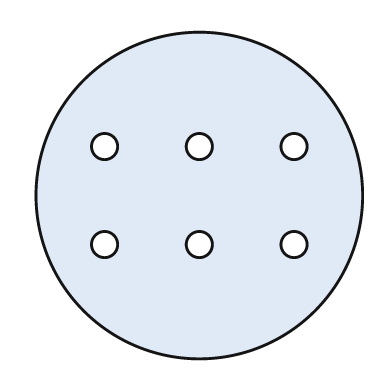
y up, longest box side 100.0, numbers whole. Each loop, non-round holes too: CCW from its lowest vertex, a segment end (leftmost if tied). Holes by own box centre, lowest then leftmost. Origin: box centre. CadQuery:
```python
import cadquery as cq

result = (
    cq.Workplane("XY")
    .moveTo(0.0, 0.0)
    .circle(50.0)
    .moveTo(-29.0, -15.0)
    .circle(4.0)
    .moveTo(0.0, -15.0)
    .circle(4.0)
    .moveTo(29.0, -15.0)
    .circle(4.0)
    .moveTo(-29.0, 15.0)
    .circle(4.0)
    .moveTo(0.0, 15.0)
    .circle(4.0)
    .moveTo(29.0, 15.0)
    .circle(4.0)
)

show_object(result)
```